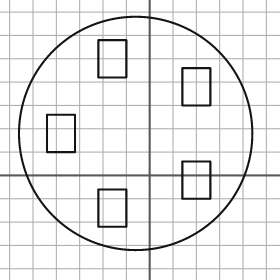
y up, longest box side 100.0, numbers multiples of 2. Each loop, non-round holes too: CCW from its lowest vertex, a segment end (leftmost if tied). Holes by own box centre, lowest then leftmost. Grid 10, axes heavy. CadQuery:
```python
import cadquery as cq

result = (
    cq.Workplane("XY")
    .moveTo(-6.0, 18.0)
    .circle(50.0)
    .moveTo(-22.0, -22.0)
    .lineTo(-10.0, -22.0)
    .lineTo(-10.0, -6.0)
    .lineTo(-22.0, -6.0)
    .close()
    .moveTo(14.0, -10.0)
    .lineTo(26.0, -10.0)
    .lineTo(26.0, 6.0)
    .lineTo(14.0, 6.0)
    .close()
    .moveTo(-44.0, 10.0)
    .lineTo(-32.0, 10.0)
    .lineTo(-32.0, 26.0)
    .lineTo(-44.0, 26.0)
    .close()
    .moveTo(14.0, 30.0)
    .lineTo(26.0, 30.0)
    .lineTo(26.0, 46.0)
    .lineTo(14.0, 46.0)
    .close()
    .moveTo(-22.0, 42.0)
    .lineTo(-10.0, 42.0)
    .lineTo(-10.0, 58.0)
    .lineTo(-22.0, 58.0)
    .close()
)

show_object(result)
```